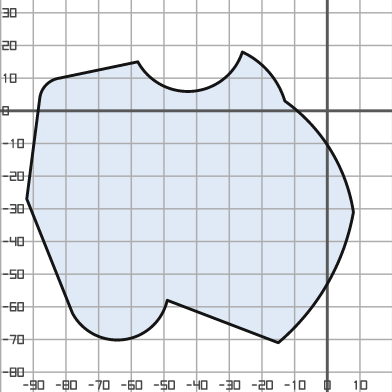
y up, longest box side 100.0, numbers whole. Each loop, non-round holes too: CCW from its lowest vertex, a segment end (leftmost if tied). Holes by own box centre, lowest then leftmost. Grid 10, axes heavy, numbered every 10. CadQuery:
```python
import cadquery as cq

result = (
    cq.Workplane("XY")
    .moveTo(-15.0, -71.0)
    .threePointArc((0.0, -53.0), (8.0, -31.0))
    .threePointArc((1.0, -12.0), (-13.0, 3.0))
    .threePointArc((-18.0, 12.0), (-26.0, 18.0))
    .threePointArc((-41.0, 6.0), (-58.0, 15.0))
    .lineTo(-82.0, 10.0)
    .threePointArc((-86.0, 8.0), (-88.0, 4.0))
    .lineTo(-92.0, -27.0)
    .lineTo(-78.0, -62.0)
    .threePointArc((-62.0, -70.0), (-49.0, -58.0))
    .close()
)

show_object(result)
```